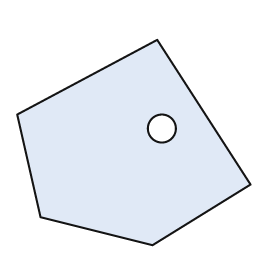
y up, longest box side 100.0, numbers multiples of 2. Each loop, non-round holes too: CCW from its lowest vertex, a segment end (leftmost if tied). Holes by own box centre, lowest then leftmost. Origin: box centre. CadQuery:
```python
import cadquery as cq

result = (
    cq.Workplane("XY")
    .moveTo(8.0, -44.0)
    .lineTo(50.0, -18.0)
    .lineTo(10.0, 44.0)
    .lineTo(-50.0, 12.0)
    .lineTo(-40.0, -32.0)
    .close()
    .moveTo(12.0, 6.0)
    .circle(6.0)
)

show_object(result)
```